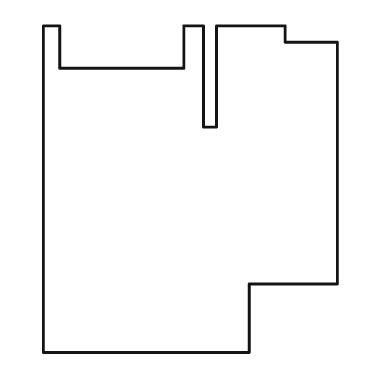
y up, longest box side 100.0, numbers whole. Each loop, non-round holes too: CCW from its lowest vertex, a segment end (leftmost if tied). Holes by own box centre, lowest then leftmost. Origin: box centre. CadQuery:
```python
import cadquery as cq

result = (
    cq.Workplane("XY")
    .moveTo(-45.0, -50.0)
    .lineTo(18.0, -50.0)
    .lineTo(18.0, -29.0)
    .lineTo(45.0, -29.0)
    .lineTo(45.0, 45.0)
    .lineTo(29.0, 45.0)
    .lineTo(29.0, 50.0)
    .lineTo(8.0, 50.0)
    .lineTo(8.0, 19.0)
    .lineTo(4.0, 19.0)
    .lineTo(4.0, 50.0)
    .lineTo(-2.0, 50.0)
    .lineTo(-2.0, 37.0)
    .lineTo(-40.0, 37.0)
    .lineTo(-40.0, 50.0)
    .lineTo(-45.0, 50.0)
    .close()
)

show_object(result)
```